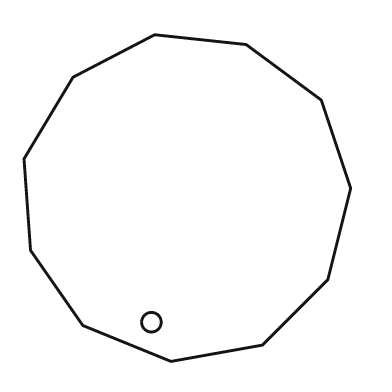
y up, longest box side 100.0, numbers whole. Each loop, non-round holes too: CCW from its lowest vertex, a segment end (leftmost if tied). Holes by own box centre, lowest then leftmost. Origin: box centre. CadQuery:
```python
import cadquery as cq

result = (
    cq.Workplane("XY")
    .moveTo(-5.0, -50.0)
    .lineTo(23.0, -45.0)
    .lineTo(43.0, -25.0)
    .lineTo(50.0, 3.0)
    .lineTo(41.0, 30.0)
    .lineTo(18.0, 47.0)
    .lineTo(-10.0, 50.0)
    .lineTo(-35.0, 37.0)
    .lineTo(-50.0, 12.0)
    .lineTo(-48.0, -16.0)
    .lineTo(-32.0, -39.0)
    .close()
    .moveTo(-11.0, -38.0)
    .circle(3.0)
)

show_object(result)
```